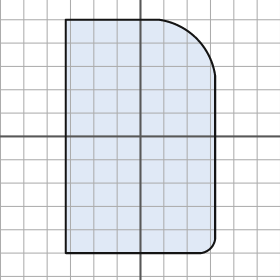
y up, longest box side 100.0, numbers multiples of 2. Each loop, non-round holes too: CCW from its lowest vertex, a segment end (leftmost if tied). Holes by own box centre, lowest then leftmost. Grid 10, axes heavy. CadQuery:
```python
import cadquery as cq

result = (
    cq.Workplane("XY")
    .moveTo(-32.0, -50.0)
    .lineTo(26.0, -50.0)
    .threePointArc((30.0, -48.0), (32.0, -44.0))
    .lineTo(32.0, 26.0)
    .threePointArc((24.0, 42.0), (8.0, 50.0))
    .lineTo(-32.0, 50.0)
    .close()
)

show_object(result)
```